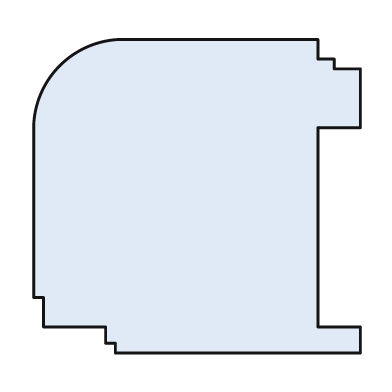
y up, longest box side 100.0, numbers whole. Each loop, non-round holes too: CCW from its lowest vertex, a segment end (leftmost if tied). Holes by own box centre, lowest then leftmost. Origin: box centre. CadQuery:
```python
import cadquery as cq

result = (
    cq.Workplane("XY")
    .moveTo(-25.0, -48.0)
    .lineTo(50.0, -48.0)
    .lineTo(50.0, -40.0)
    .lineTo(37.0, -40.0)
    .lineTo(37.0, 21.0)
    .lineTo(50.0, 21.0)
    .lineTo(50.0, 39.0)
    .lineTo(42.0, 39.0)
    .lineTo(42.0, 42.0)
    .lineTo(37.0, 42.0)
    .lineTo(37.0, 48.0)
    .lineTo(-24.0, 48.0)
    .threePointArc((-42.0, 40.0), (-50.0, 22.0))
    .lineTo(-50.0, -31.0)
    .lineTo(-47.0, -31.0)
    .lineTo(-47.0, -40.0)
    .lineTo(-28.0, -40.0)
    .lineTo(-28.0, -45.0)
    .lineTo(-25.0, -45.0)
    .close()
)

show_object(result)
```